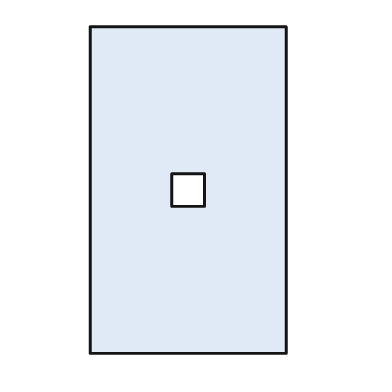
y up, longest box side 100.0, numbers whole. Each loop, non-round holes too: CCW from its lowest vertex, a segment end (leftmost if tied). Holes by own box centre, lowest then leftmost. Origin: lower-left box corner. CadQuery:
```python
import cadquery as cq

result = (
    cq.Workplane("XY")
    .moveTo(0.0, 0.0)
    .lineTo(60.0, 0.0)
    .lineTo(60.0, 100.0)
    .lineTo(0.0, 100.0)
    .close()
    .moveTo(25.0, 45.0)
    .lineTo(35.0, 45.0)
    .lineTo(35.0, 55.0)
    .lineTo(25.0, 55.0)
    .close()
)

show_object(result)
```